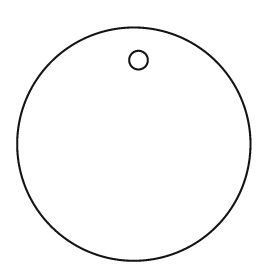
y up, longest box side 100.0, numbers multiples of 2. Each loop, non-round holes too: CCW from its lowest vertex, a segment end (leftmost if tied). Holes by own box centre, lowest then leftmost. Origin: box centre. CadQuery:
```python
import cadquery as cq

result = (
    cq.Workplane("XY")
    .moveTo(0.0, 0.0)
    .circle(50.0)
    .moveTo(2.0, 36.0)
    .circle(4.0)
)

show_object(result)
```